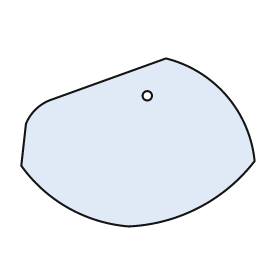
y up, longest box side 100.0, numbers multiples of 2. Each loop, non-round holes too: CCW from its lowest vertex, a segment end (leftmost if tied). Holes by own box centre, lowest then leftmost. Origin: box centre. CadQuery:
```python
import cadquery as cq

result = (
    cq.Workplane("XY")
    .moveTo(-4.0, -36.0)
    .threePointArc((26.0, -28.0), (50.0, -8.0))
    .threePointArc((38.0, 20.0), (12.0, 36.0))
    .lineTo(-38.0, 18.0)
    .threePointArc((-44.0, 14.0), (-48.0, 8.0))
    .lineTo(-50.0, -10.0)
    .threePointArc((-30.0, -28.0), (-4.0, -36.0))
    .close()
    .moveTo(4.0, 20.0)
    .circle(2.0)
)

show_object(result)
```